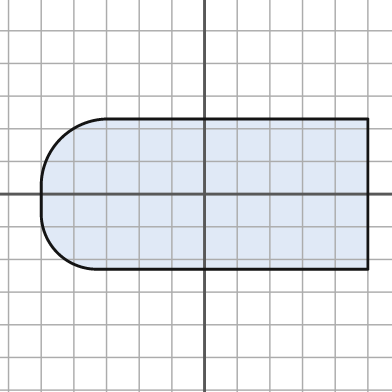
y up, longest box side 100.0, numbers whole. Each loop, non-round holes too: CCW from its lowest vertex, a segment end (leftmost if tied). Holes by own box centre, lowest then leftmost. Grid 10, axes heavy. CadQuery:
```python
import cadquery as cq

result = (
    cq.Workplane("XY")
    .moveTo(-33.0, -23.0)
    .lineTo(50.0, -23.0)
    .lineTo(50.0, 23.0)
    .lineTo(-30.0, 23.0)
    .threePointArc((-44.0, 17.0), (-50.0, 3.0))
    .lineTo(-50.0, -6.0)
    .threePointArc((-45.0, -18.0), (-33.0, -23.0))
    .close()
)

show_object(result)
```